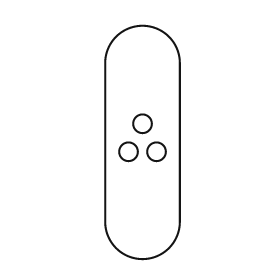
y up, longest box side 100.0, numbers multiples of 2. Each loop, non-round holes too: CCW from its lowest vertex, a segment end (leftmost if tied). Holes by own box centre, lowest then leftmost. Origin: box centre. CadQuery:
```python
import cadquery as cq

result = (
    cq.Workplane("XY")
    .moveTo(-16.0, -34.0)
    .threePointArc((0.0, -50.0), (16.0, -34.0))
    .lineTo(16.0, 34.0)
    .threePointArc((0.0, 50.0), (-16.0, 34.0))
    .close()
    .moveTo(-6.0, -4.0)
    .circle(4.0)
    .moveTo(6.0, -4.0)
    .circle(4.0)
    .moveTo(0.0, 8.0)
    .circle(4.0)
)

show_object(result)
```